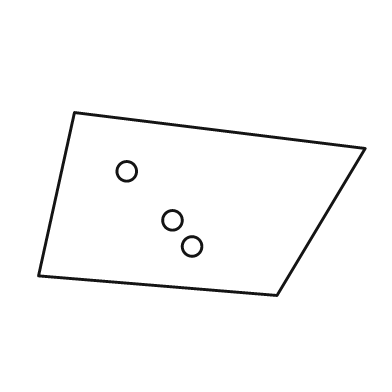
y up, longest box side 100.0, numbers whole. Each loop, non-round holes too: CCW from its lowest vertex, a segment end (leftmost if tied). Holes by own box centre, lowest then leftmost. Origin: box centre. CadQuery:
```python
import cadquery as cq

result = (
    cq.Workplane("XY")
    .moveTo(23.0, -28.0)
    .lineTo(50.0, 17.0)
    .lineTo(-39.0, 28.0)
    .lineTo(-50.0, -22.0)
    .close()
    .moveTo(-3.0, -13.0)
    .circle(3.0)
    .moveTo(-9.0, -5.0)
    .circle(3.0)
    .moveTo(-23.0, 10.0)
    .circle(3.0)
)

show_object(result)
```